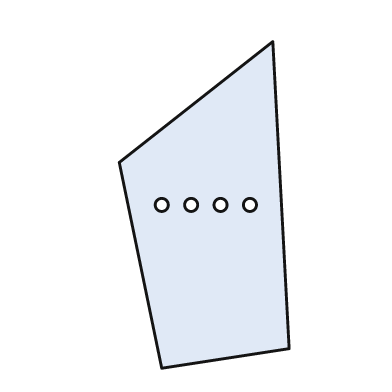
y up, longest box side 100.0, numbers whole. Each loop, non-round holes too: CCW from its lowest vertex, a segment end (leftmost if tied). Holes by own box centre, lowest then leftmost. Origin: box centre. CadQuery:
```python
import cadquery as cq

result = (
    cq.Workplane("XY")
    .moveTo(-13.0, -50.0)
    .lineTo(26.0, -44.0)
    .lineTo(21.0, 50.0)
    .lineTo(-26.0, 13.0)
    .close()
    .moveTo(-13.0, 0.0)
    .circle(2.0)
    .moveTo(-4.0, 0.0)
    .circle(2.0)
    .moveTo(5.0, 0.0)
    .circle(2.0)
    .moveTo(14.0, 0.0)
    .circle(2.0)
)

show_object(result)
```